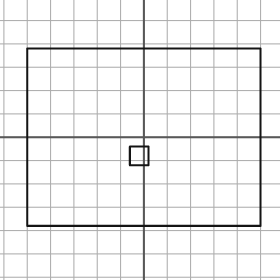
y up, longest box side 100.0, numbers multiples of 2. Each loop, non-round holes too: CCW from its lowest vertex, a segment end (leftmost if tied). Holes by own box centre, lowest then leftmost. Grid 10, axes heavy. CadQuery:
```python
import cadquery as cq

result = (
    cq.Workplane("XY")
    .moveTo(-50.0, -38.0)
    .lineTo(50.0, -38.0)
    .lineTo(50.0, 38.0)
    .lineTo(-50.0, 38.0)
    .close()
    .moveTo(-6.0, -12.0)
    .lineTo(2.0, -12.0)
    .lineTo(2.0, -4.0)
    .lineTo(-6.0, -4.0)
    .close()
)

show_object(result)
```